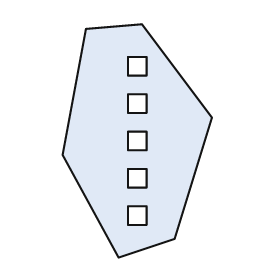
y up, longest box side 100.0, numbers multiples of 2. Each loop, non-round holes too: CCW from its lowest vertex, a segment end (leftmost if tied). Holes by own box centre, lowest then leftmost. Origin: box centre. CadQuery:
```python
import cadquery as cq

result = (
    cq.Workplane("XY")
    .moveTo(-8.0, -50.0)
    .lineTo(16.0, -42.0)
    .lineTo(32.0, 10.0)
    .lineTo(2.0, 50.0)
    .lineTo(-22.0, 48.0)
    .lineTo(-32.0, -6.0)
    .close()
    .moveTo(-4.0, -36.0)
    .lineTo(4.0, -36.0)
    .lineTo(4.0, -28.0)
    .lineTo(-4.0, -28.0)
    .close()
    .moveTo(-4.0, -20.0)
    .lineTo(4.0, -20.0)
    .lineTo(4.0, -12.0)
    .lineTo(-4.0, -12.0)
    .close()
    .moveTo(-4.0, -4.0)
    .lineTo(4.0, -4.0)
    .lineTo(4.0, 4.0)
    .lineTo(-4.0, 4.0)
    .close()
    .moveTo(-4.0, 12.0)
    .lineTo(4.0, 12.0)
    .lineTo(4.0, 20.0)
    .lineTo(-4.0, 20.0)
    .close()
    .moveTo(-4.0, 28.0)
    .lineTo(4.0, 28.0)
    .lineTo(4.0, 36.0)
    .lineTo(-4.0, 36.0)
    .close()
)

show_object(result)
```